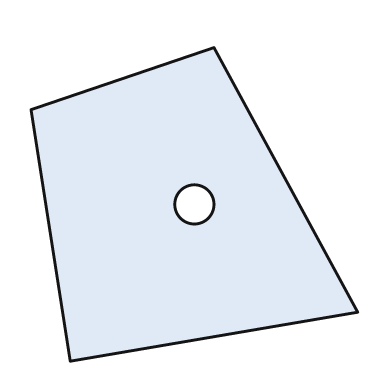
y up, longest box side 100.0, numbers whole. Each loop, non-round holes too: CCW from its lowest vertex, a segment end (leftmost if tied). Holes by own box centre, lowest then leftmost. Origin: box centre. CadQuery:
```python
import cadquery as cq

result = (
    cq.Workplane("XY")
    .moveTo(-38.0, -48.0)
    .lineTo(50.0, -33.0)
    .lineTo(6.0, 48.0)
    .lineTo(-50.0, 29.0)
    .close()
    .moveTo(0.0, 0.0)
    .circle(6.0)
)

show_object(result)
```